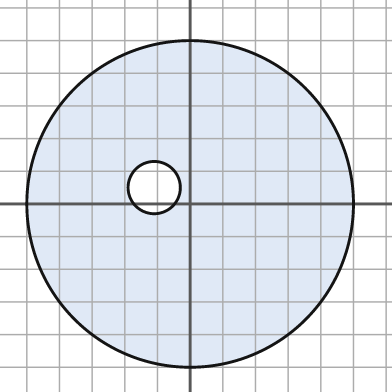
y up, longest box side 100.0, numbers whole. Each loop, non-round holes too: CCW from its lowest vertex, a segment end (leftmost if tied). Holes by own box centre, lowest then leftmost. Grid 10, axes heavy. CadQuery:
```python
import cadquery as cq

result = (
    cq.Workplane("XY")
    .moveTo(0.0, 0.0)
    .circle(50.0)
    .moveTo(-11.0, 5.0)
    .circle(8.0)
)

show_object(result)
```